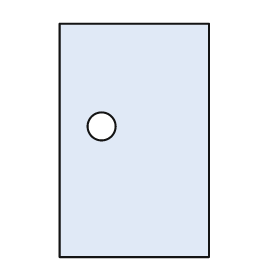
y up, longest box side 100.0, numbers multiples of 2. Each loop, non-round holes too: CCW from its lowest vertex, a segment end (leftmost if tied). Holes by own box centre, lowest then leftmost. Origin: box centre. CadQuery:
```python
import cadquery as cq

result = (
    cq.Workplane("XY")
    .moveTo(-32.0, -50.0)
    .lineTo(32.0, -50.0)
    .lineTo(32.0, 50.0)
    .lineTo(-32.0, 50.0)
    .close()
    .moveTo(-14.0, 6.0)
    .circle(6.0)
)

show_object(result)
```